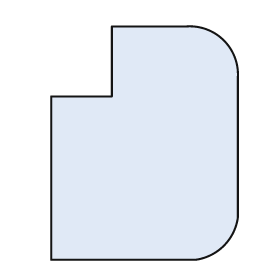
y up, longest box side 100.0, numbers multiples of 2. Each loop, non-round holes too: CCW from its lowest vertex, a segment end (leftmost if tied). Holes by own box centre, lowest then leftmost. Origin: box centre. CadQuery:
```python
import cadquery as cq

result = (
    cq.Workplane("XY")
    .moveTo(-40.0, -50.0)
    .lineTo(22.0, -50.0)
    .threePointArc((34.0, -44.0), (40.0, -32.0))
    .lineTo(40.0, 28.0)
    .threePointArc((34.0, 44.0), (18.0, 50.0))
    .lineTo(-14.0, 50.0)
    .lineTo(-14.0, 20.0)
    .lineTo(-40.0, 20.0)
    .close()
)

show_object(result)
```